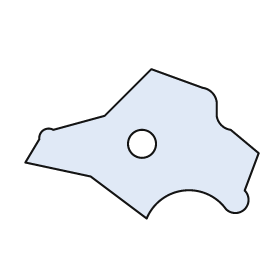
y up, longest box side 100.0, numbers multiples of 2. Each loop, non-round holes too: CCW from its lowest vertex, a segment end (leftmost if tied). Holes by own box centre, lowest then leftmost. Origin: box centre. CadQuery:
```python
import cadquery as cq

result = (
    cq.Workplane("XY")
    .moveTo(2.0, -32.0)
    .threePointArc((18.0, -20.0), (36.0, -28.0))
    .threePointArc((44.0, -28.0), (44.0, -20.0))
    .lineTo(50.0, -4.0)
    .lineTo(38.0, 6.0)
    .threePointArc((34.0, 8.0), (32.0, 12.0))
    .lineTo(32.0, 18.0)
    .threePointArc((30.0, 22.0), (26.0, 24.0))
    .lineTo(4.0, 32.0)
    .lineTo(-16.0, 12.0)
    .lineTo(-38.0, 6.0)
    .threePointArc((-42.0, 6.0), (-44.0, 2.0))
    .lineTo(-50.0, -8.0)
    .lineTo(-22.0, -14.0)
    .close()
    .moveTo(0.0, 0.0)
    .circle(6.0)
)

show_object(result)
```